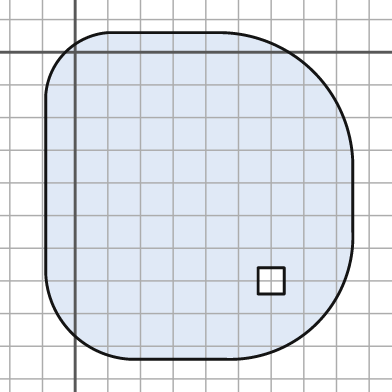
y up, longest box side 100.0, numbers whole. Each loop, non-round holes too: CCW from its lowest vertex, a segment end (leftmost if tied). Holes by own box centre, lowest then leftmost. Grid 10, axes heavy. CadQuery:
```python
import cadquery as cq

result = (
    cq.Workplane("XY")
    .moveTo(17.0, -94.0)
    .lineTo(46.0, -94.0)
    .threePointArc((74.0, -83.0), (85.0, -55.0))
    .lineTo(85.0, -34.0)
    .threePointArc((73.0, -6.0), (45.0, 6.0))
    .lineTo(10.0, 6.0)
    .threePointArc((-3.0, 0.0), (-9.0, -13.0))
    .lineTo(-9.0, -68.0)
    .threePointArc((-1.0, -86.0), (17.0, -94.0))
    .close()
    .moveTo(56.0, -74.0)
    .lineTo(64.0, -74.0)
    .lineTo(64.0, -66.0)
    .lineTo(56.0, -66.0)
    .close()
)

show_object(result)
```